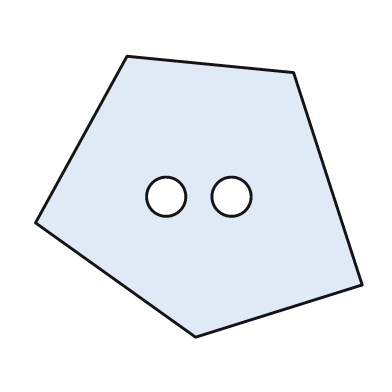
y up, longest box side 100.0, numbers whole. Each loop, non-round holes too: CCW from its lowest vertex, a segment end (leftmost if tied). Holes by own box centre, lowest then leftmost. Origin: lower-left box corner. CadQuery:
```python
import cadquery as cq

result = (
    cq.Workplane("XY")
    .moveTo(49.0, 0.0)
    .lineTo(100.0, 16.0)
    .lineTo(79.0, 81.0)
    .lineTo(28.0, 86.0)
    .lineTo(0.0, 35.0)
    .close()
    .moveTo(40.0, 43.0)
    .circle(6.0)
    .moveTo(60.0, 43.0)
    .circle(6.0)
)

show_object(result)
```